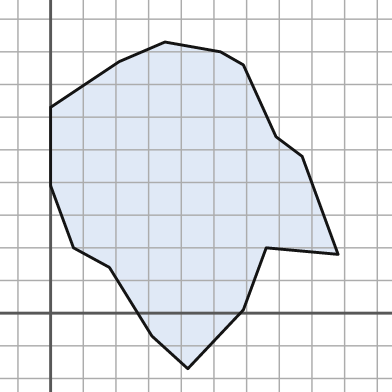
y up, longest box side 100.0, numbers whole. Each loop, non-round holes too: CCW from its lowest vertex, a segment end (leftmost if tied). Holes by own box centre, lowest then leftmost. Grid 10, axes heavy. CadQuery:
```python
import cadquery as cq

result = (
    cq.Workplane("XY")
    .moveTo(42.0, -17.0)
    .lineTo(59.0, 1.0)
    .lineTo(66.0, 20.0)
    .lineTo(88.0, 18.0)
    .lineTo(77.0, 48.0)
    .lineTo(69.0, 54.0)
    .lineTo(59.0, 76.0)
    .lineTo(52.0, 80.0)
    .lineTo(35.0, 83.0)
    .lineTo(21.0, 77.0)
    .lineTo(0.0, 63.0)
    .lineTo(0.0, 39.0)
    .lineTo(7.0, 20.0)
    .lineTo(18.0, 14.0)
    .lineTo(31.0, -7.0)
    .close()
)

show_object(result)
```